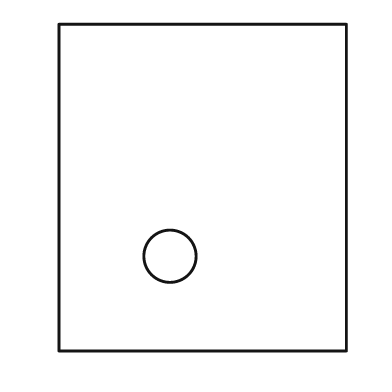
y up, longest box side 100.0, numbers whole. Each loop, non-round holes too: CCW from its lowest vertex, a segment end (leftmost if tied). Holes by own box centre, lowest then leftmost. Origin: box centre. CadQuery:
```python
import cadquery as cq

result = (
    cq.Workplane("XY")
    .moveTo(-44.0, -50.0)
    .lineTo(44.0, -50.0)
    .lineTo(44.0, 50.0)
    .lineTo(-44.0, 50.0)
    .close()
    .moveTo(-10.0, -21.0)
    .circle(8.0)
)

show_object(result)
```